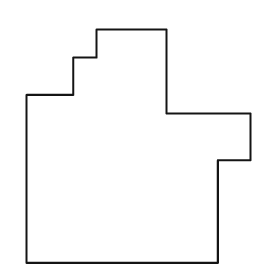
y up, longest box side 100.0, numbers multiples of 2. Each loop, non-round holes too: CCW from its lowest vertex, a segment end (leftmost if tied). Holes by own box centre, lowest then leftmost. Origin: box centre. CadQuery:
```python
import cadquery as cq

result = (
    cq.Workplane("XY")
    .moveTo(-48.0, -50.0)
    .lineTo(34.0, -50.0)
    .lineTo(34.0, -6.0)
    .lineTo(48.0, -6.0)
    .lineTo(48.0, 14.0)
    .lineTo(12.0, 14.0)
    .lineTo(12.0, 50.0)
    .lineTo(-18.0, 50.0)
    .lineTo(-18.0, 38.0)
    .lineTo(-28.0, 38.0)
    .lineTo(-28.0, 22.0)
    .lineTo(-48.0, 22.0)
    .close()
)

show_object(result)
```